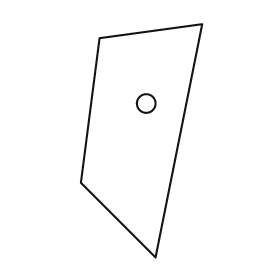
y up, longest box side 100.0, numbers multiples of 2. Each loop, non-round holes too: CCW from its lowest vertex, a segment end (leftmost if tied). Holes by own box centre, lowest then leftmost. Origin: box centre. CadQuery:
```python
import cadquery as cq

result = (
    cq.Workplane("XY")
    .moveTo(6.0, -50.0)
    .lineTo(26.0, 50.0)
    .lineTo(-18.0, 44.0)
    .lineTo(-26.0, -18.0)
    .close()
    .moveTo(2.0, 16.0)
    .circle(4.0)
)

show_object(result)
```